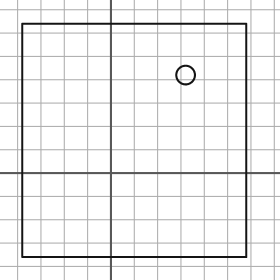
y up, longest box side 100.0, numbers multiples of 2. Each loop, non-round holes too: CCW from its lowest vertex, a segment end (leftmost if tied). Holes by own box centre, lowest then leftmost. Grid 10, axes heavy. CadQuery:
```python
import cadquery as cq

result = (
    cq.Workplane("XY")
    .moveTo(-38.0, -36.0)
    .lineTo(58.0, -36.0)
    .lineTo(58.0, 64.0)
    .lineTo(-38.0, 64.0)
    .close()
    .moveTo(32.0, 42.0)
    .circle(4.0)
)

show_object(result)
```